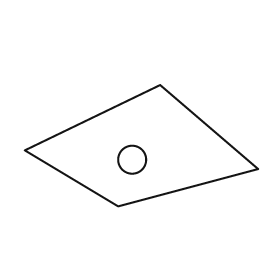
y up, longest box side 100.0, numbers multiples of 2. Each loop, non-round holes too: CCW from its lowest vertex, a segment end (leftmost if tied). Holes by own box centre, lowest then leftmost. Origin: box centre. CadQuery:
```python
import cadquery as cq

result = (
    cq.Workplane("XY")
    .moveTo(-10.0, -26.0)
    .lineTo(50.0, -10.0)
    .lineTo(8.0, 26.0)
    .lineTo(-50.0, -2.0)
    .close()
    .moveTo(-4.0, -6.0)
    .circle(6.0)
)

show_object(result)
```